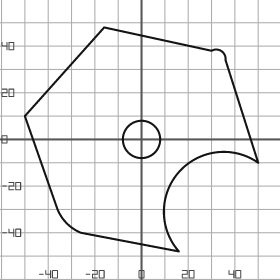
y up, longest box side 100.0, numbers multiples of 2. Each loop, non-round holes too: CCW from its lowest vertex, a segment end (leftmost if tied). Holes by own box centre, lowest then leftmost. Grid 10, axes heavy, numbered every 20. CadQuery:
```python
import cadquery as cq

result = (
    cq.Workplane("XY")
    .moveTo(16.0, -48.0)
    .threePointArc((16.0, -14.0), (50.0, -10.0))
    .lineTo(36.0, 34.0)
    .threePointArc((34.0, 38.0), (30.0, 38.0))
    .lineTo(-16.0, 48.0)
    .lineTo(-50.0, 10.0)
    .lineTo(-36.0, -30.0)
    .threePointArc((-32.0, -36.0), (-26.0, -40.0))
    .close()
    .moveTo(0.0, 0.0)
    .circle(8.0)
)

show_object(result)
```